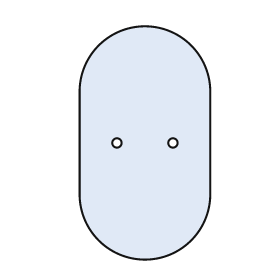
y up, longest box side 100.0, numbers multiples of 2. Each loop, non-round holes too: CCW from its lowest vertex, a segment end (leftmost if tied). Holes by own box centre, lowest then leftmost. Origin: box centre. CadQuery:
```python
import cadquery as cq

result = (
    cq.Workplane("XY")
    .moveTo(-28.0, -22.0)
    .threePointArc((0.0, -50.0), (28.0, -22.0))
    .lineTo(28.0, 22.0)
    .threePointArc((0.0, 50.0), (-28.0, 22.0))
    .close()
    .moveTo(-12.0, 0.0)
    .circle(2.0)
    .moveTo(12.0, 0.0)
    .circle(2.0)
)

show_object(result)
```